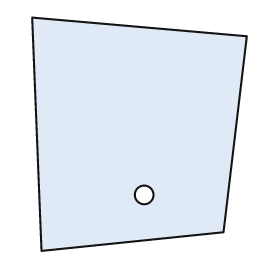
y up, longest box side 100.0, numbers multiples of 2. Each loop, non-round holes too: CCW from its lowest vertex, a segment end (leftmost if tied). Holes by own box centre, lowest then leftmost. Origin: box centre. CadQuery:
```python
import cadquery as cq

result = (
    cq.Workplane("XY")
    .moveTo(-42.0, -50.0)
    .lineTo(36.0, -42.0)
    .lineTo(46.0, 42.0)
    .lineTo(-46.0, 50.0)
    .close()
    .moveTo(2.0, -26.0)
    .circle(4.0)
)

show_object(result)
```